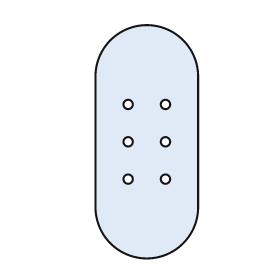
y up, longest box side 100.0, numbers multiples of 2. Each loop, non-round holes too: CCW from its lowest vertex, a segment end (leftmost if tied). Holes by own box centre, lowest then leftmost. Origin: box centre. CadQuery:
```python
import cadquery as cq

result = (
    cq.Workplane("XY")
    .moveTo(-22.0, -28.0)
    .threePointArc((0.0, -50.0), (22.0, -28.0))
    .lineTo(22.0, 28.0)
    .threePointArc((0.0, 50.0), (-22.0, 28.0))
    .close()
    .moveTo(-8.0, -16.0)
    .circle(2.0)
    .moveTo(8.0, -16.0)
    .circle(2.0)
    .moveTo(-8.0, 0.0)
    .circle(2.0)
    .moveTo(8.0, 0.0)
    .circle(2.0)
    .moveTo(-8.0, 16.0)
    .circle(2.0)
    .moveTo(8.0, 16.0)
    .circle(2.0)
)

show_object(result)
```